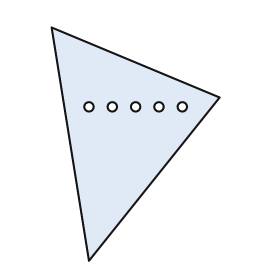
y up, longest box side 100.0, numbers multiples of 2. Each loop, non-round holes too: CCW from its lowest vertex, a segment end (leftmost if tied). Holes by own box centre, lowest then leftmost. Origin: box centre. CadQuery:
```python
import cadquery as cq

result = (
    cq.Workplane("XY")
    .moveTo(-20.0, -50.0)
    .lineTo(36.0, 20.0)
    .lineTo(-36.0, 50.0)
    .close()
    .moveTo(-20.0, 16.0)
    .circle(2.0)
    .moveTo(-10.0, 16.0)
    .circle(2.0)
    .moveTo(0.0, 16.0)
    .circle(2.0)
    .moveTo(10.0, 16.0)
    .circle(2.0)
    .moveTo(20.0, 16.0)
    .circle(2.0)
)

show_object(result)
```